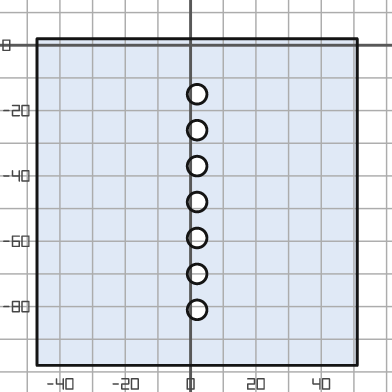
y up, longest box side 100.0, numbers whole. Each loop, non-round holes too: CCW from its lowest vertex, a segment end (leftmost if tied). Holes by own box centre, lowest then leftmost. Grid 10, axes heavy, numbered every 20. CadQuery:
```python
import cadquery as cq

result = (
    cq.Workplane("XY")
    .moveTo(-47.0, -98.0)
    .lineTo(51.0, -98.0)
    .lineTo(51.0, 2.0)
    .lineTo(-47.0, 2.0)
    .close()
    .moveTo(2.0, -81.0)
    .circle(3.0)
    .moveTo(2.0, -70.0)
    .circle(3.0)
    .moveTo(2.0, -59.0)
    .circle(3.0)
    .moveTo(2.0, -48.0)
    .circle(3.0)
    .moveTo(2.0, -37.0)
    .circle(3.0)
    .moveTo(2.0, -26.0)
    .circle(3.0)
    .moveTo(2.0, -15.0)
    .circle(3.0)
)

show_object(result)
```